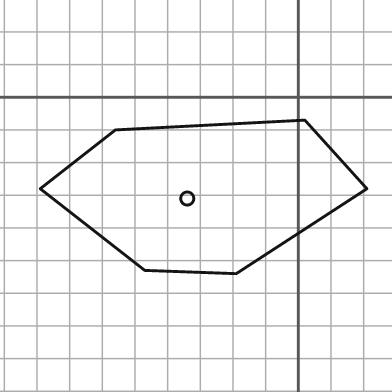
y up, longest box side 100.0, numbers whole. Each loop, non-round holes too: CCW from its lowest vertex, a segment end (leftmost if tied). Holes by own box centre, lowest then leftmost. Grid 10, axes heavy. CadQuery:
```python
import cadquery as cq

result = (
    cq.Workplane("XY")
    .moveTo(-19.0, -54.0)
    .lineTo(21.0, -28.0)
    .lineTo(2.0, -7.0)
    .lineTo(-56.0, -10.0)
    .lineTo(-79.0, -28.0)
    .lineTo(-47.0, -53.0)
    .close()
    .moveTo(-34.0, -31.0)
    .circle(2.0)
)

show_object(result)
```